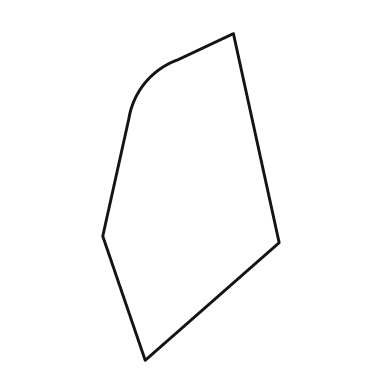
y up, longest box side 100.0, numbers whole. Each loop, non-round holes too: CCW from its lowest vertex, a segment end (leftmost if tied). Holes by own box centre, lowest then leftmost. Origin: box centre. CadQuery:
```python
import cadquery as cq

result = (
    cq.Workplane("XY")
    .moveTo(-14.0, -50.0)
    .lineTo(27.0, -14.0)
    .lineTo(13.0, 50.0)
    .lineTo(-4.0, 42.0)
    .threePointArc((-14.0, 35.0), (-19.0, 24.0))
    .lineTo(-27.0, -12.0)
    .close()
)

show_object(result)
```